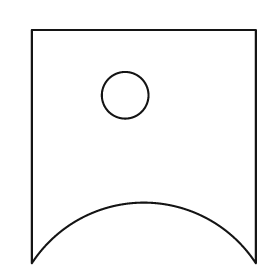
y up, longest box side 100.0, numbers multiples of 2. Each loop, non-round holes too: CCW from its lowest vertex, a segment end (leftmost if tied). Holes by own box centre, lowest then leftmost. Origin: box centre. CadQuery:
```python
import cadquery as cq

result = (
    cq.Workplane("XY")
    .moveTo(-48.0, -50.0)
    .threePointArc((0.0, -24.0), (48.0, -50.0))
    .lineTo(48.0, 50.0)
    .lineTo(-48.0, 50.0)
    .close()
    .moveTo(-8.0, 22.0)
    .circle(10.0)
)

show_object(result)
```